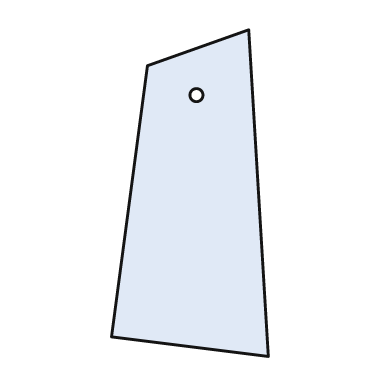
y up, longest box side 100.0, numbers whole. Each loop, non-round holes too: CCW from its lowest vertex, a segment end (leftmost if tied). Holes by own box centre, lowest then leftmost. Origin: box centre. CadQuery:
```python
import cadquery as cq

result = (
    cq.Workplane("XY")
    .moveTo(24.0, -50.0)
    .lineTo(18.0, 50.0)
    .lineTo(-13.0, 39.0)
    .lineTo(-24.0, -44.0)
    .close()
    .moveTo(2.0, 30.0)
    .circle(2.0)
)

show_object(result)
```